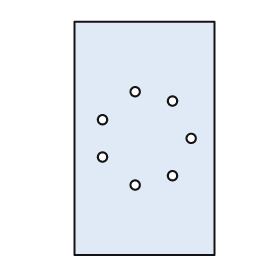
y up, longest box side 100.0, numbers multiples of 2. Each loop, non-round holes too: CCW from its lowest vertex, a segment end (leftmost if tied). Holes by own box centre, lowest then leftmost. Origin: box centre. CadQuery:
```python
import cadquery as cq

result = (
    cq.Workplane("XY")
    .moveTo(-30.0, -50.0)
    .lineTo(30.0, -50.0)
    .lineTo(30.0, 50.0)
    .lineTo(-30.0, 50.0)
    .close()
    .moveTo(-4.0, -20.0)
    .circle(2.0)
    .moveTo(12.0, -16.0)
    .circle(2.0)
    .moveTo(-18.0, -8.0)
    .circle(2.0)
    .moveTo(20.0, 0.0)
    .circle(2.0)
    .moveTo(-18.0, 8.0)
    .circle(2.0)
    .moveTo(12.0, 16.0)
    .circle(2.0)
    .moveTo(-4.0, 20.0)
    .circle(2.0)
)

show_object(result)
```